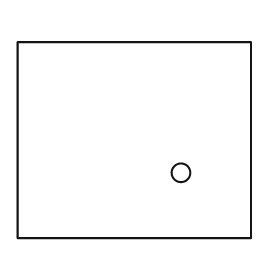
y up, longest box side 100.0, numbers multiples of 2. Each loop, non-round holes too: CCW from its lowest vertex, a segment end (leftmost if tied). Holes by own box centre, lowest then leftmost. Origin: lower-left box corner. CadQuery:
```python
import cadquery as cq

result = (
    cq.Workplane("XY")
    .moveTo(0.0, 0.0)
    .lineTo(100.0, 0.0)
    .lineTo(100.0, 84.0)
    .lineTo(0.0, 84.0)
    .close()
    .moveTo(70.0, 28.0)
    .circle(4.0)
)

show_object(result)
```